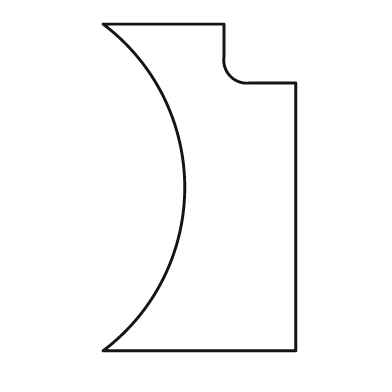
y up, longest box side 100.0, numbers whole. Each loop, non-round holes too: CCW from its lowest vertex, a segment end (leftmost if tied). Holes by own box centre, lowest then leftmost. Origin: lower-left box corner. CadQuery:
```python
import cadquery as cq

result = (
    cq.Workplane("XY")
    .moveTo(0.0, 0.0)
    .lineTo(59.0, 0.0)
    .lineTo(59.0, 82.0)
    .lineTo(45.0, 82.0)
    .threePointArc((39.0, 84.0), (37.0, 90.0))
    .lineTo(37.0, 100.0)
    .lineTo(0.0, 100.0)
    .threePointArc((25.0, 50.0), (0.0, 0.0))
    .close()
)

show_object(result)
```